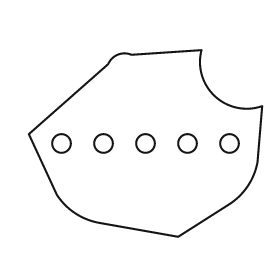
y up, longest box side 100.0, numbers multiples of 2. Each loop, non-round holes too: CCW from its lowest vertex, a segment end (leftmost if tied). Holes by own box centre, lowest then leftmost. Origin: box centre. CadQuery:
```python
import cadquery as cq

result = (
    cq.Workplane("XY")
    .moveTo(14.0, -40.0)
    .lineTo(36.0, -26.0)
    .threePointArc((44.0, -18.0), (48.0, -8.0))
    .lineTo(50.0, 16.0)
    .threePointArc((30.0, 20.0), (24.0, 40.0))
    .lineTo(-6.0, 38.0)
    .threePointArc((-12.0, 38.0), (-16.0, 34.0))
    .lineTo(-50.0, 4.0)
    .lineTo(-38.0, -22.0)
    .threePointArc((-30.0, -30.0), (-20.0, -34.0))
    .close()
    .moveTo(-36.0, 0.0)
    .circle(4.0)
    .moveTo(-18.0, 0.0)
    .circle(4.0)
    .moveTo(0.0, 0.0)
    .circle(4.0)
    .moveTo(18.0, 0.0)
    .circle(4.0)
    .moveTo(36.0, 0.0)
    .circle(4.0)
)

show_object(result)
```